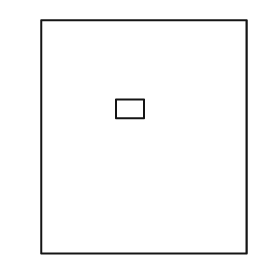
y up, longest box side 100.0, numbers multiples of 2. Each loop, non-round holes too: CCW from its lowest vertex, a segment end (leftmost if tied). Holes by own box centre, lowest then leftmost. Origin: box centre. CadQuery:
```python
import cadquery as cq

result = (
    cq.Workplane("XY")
    .moveTo(-44.0, -50.0)
    .lineTo(44.0, -50.0)
    .lineTo(44.0, 50.0)
    .lineTo(-44.0, 50.0)
    .close()
    .moveTo(-12.0, 8.0)
    .lineTo(0.0, 8.0)
    .lineTo(0.0, 16.0)
    .lineTo(-12.0, 16.0)
    .close()
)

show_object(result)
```